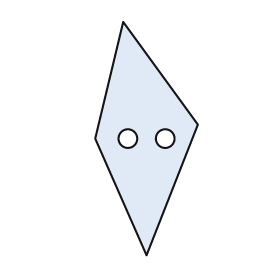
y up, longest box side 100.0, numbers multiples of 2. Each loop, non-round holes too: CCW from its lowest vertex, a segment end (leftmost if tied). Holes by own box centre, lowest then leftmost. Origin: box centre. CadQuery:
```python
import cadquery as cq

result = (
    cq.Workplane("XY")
    .moveTo(0.0, -50.0)
    .lineTo(22.0, 6.0)
    .lineTo(-10.0, 50.0)
    .lineTo(-22.0, 0.0)
    .close()
    .moveTo(-8.0, 0.0)
    .circle(4.0)
    .moveTo(8.0, 0.0)
    .circle(4.0)
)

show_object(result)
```